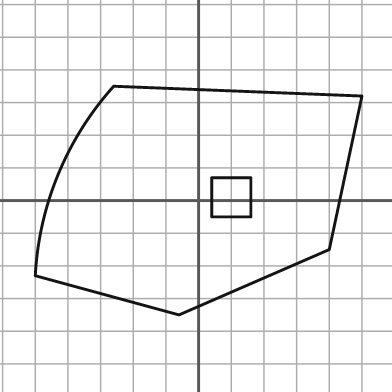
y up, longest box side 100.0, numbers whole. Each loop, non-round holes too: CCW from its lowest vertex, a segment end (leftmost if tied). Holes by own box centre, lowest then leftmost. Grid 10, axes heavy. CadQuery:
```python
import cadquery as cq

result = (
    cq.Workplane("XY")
    .moveTo(-6.0, -35.0)
    .lineTo(40.0, -15.0)
    .lineTo(50.0, 32.0)
    .lineTo(-26.0, 35.0)
    .threePointArc((-43.0, 8.0), (-50.0, -23.0))
    .close()
    .moveTo(4.0, -5.0)
    .lineTo(16.0, -5.0)
    .lineTo(16.0, 7.0)
    .lineTo(4.0, 7.0)
    .close()
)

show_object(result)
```